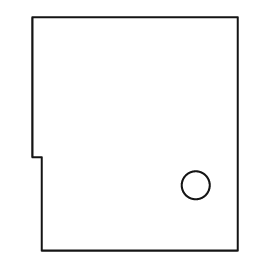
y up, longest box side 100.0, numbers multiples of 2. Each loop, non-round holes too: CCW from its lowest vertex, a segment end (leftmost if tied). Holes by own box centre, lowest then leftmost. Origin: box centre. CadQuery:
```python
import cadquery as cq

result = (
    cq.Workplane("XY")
    .moveTo(-40.0, -50.0)
    .lineTo(44.0, -50.0)
    .lineTo(44.0, 50.0)
    .lineTo(-44.0, 50.0)
    .lineTo(-44.0, -10.0)
    .lineTo(-40.0, -10.0)
    .close()
    .moveTo(26.0, -22.0)
    .circle(6.0)
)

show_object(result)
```